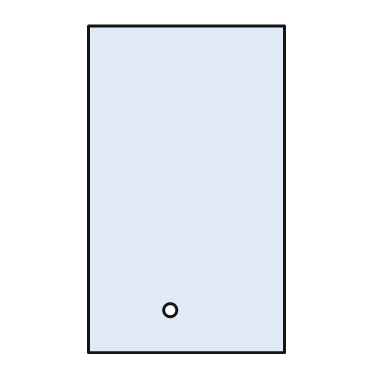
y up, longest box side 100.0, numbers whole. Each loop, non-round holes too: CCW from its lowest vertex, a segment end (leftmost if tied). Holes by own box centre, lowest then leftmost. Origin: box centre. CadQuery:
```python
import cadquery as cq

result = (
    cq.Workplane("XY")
    .moveTo(-30.0, -50.0)
    .lineTo(30.0, -50.0)
    .lineTo(30.0, 50.0)
    .lineTo(-30.0, 50.0)
    .close()
    .moveTo(-5.0, -37.0)
    .circle(2.0)
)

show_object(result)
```